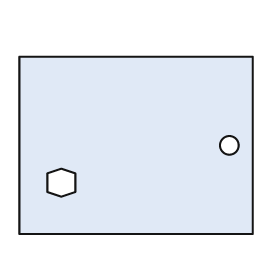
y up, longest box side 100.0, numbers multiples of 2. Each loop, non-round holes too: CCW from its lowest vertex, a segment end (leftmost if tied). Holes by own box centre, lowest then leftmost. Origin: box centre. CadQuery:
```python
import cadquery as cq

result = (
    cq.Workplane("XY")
    .moveTo(-50.0, -38.0)
    .lineTo(50.0, -38.0)
    .lineTo(50.0, 38.0)
    .lineTo(-50.0, 38.0)
    .close()
    .moveTo(-32.0, -22.0)
    .lineTo(-26.0, -20.0)
    .lineTo(-26.0, -12.0)
    .lineTo(-32.0, -10.0)
    .lineTo(-38.0, -12.0)
    .lineTo(-38.0, -20.0)
    .close()
    .moveTo(40.0, 0.0)
    .circle(4.0)
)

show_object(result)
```